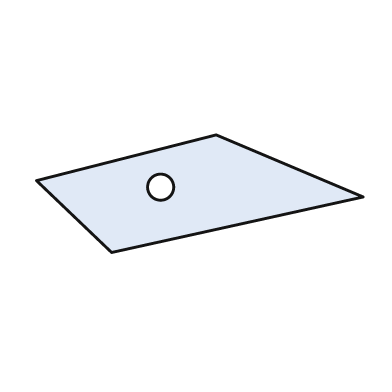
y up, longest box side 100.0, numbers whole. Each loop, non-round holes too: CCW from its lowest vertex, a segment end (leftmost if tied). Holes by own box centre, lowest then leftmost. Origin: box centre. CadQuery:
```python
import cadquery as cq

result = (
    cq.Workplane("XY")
    .moveTo(-27.0, -18.0)
    .lineTo(50.0, -1.0)
    .lineTo(5.0, 18.0)
    .lineTo(-50.0, 4.0)
    .close()
    .moveTo(-12.0, 2.0)
    .circle(4.0)
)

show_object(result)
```